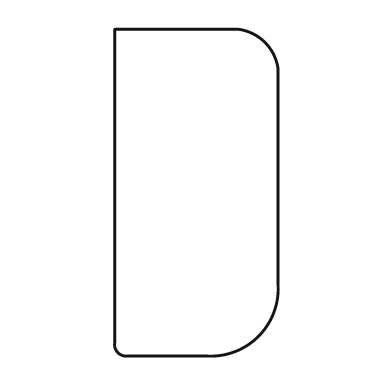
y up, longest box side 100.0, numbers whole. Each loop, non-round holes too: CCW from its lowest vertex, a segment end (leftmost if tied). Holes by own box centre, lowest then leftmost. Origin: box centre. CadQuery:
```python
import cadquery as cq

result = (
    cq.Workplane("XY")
    .moveTo(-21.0, -50.0)
    .lineTo(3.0, -50.0)
    .threePointArc((19.0, -44.0), (25.0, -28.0))
    .lineTo(25.0, 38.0)
    .threePointArc((21.0, 46.0), (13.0, 50.0))
    .lineTo(-25.0, 50.0)
    .lineTo(-25.0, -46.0)
    .threePointArc((-24.0, -49.0), (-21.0, -50.0))
    .close()
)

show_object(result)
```